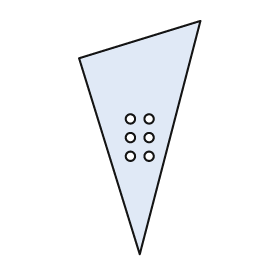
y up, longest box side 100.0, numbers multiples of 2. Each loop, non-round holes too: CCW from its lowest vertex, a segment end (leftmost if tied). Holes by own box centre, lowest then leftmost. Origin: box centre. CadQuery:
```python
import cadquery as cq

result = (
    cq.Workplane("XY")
    .moveTo(0.0, -50.0)
    .lineTo(26.0, 50.0)
    .lineTo(-26.0, 34.0)
    .close()
    .moveTo(-4.0, -8.0)
    .circle(2.0)
    .moveTo(4.0, -8.0)
    .circle(2.0)
    .moveTo(-4.0, 0.0)
    .circle(2.0)
    .moveTo(4.0, 0.0)
    .circle(2.0)
    .moveTo(-4.0, 8.0)
    .circle(2.0)
    .moveTo(4.0, 8.0)
    .circle(2.0)
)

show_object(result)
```